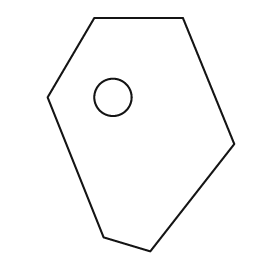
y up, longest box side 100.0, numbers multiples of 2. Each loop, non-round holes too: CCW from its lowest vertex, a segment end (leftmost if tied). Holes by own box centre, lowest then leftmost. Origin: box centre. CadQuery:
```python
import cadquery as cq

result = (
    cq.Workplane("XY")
    .moveTo(4.0, -50.0)
    .lineTo(40.0, -4.0)
    .lineTo(18.0, 50.0)
    .lineTo(-20.0, 50.0)
    .lineTo(-40.0, 16.0)
    .lineTo(-16.0, -44.0)
    .close()
    .moveTo(-12.0, 16.0)
    .circle(8.0)
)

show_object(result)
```